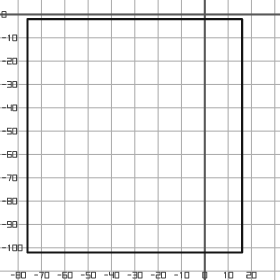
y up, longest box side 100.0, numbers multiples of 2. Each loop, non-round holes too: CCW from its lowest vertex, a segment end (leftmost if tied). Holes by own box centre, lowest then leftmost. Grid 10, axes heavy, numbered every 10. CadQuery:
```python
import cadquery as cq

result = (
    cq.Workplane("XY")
    .moveTo(-76.0, -102.0)
    .lineTo(16.0, -102.0)
    .lineTo(16.0, -2.0)
    .lineTo(-76.0, -2.0)
    .close()
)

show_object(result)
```